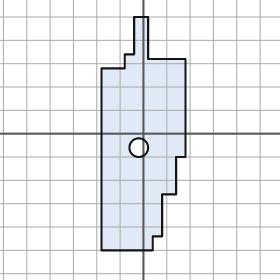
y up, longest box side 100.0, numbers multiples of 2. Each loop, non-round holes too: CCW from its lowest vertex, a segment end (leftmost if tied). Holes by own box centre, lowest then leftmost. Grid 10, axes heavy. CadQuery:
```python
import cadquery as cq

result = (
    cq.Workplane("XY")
    .moveTo(-18.0, -50.0)
    .lineTo(4.0, -50.0)
    .lineTo(4.0, -44.0)
    .lineTo(8.0, -44.0)
    .lineTo(8.0, -26.0)
    .lineTo(14.0, -26.0)
    .lineTo(14.0, -10.0)
    .lineTo(18.0, -10.0)
    .lineTo(18.0, 32.0)
    .lineTo(2.0, 32.0)
    .lineTo(2.0, 50.0)
    .lineTo(-4.0, 50.0)
    .lineTo(-4.0, 34.0)
    .lineTo(-8.0, 34.0)
    .lineTo(-8.0, 28.0)
    .lineTo(-18.0, 28.0)
    .close()
    .moveTo(-2.0, -6.0)
    .circle(4.0)
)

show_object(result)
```